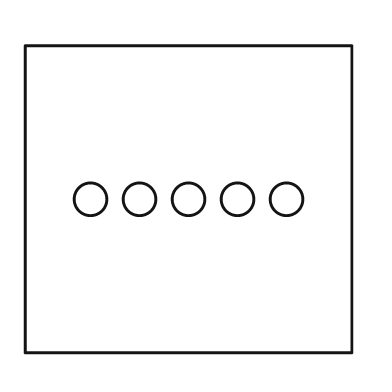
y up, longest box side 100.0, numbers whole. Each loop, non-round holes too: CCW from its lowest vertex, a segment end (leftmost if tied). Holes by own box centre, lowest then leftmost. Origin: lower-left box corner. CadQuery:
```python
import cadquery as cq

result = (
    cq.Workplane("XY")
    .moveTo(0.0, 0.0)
    .lineTo(100.0, 0.0)
    .lineTo(100.0, 94.0)
    .lineTo(0.0, 94.0)
    .close()
    .moveTo(20.0, 47.0)
    .circle(5.0)
    .moveTo(35.0, 47.0)
    .circle(5.0)
    .moveTo(50.0, 47.0)
    .circle(5.0)
    .moveTo(65.0, 47.0)
    .circle(5.0)
    .moveTo(80.0, 47.0)
    .circle(5.0)
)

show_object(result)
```